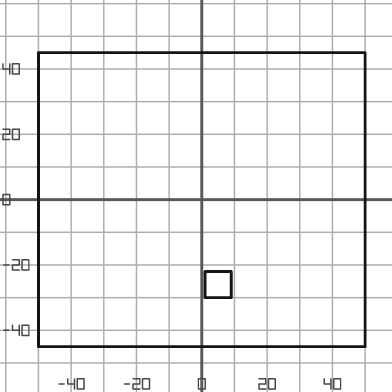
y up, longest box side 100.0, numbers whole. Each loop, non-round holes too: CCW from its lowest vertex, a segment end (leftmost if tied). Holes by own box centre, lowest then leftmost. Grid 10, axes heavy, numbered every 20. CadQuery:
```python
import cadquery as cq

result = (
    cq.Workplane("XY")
    .moveTo(-50.0, -45.0)
    .lineTo(50.0, -45.0)
    .lineTo(50.0, 45.0)
    .lineTo(-50.0, 45.0)
    .close()
    .moveTo(1.0, -30.0)
    .lineTo(9.0, -30.0)
    .lineTo(9.0, -22.0)
    .lineTo(1.0, -22.0)
    .close()
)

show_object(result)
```